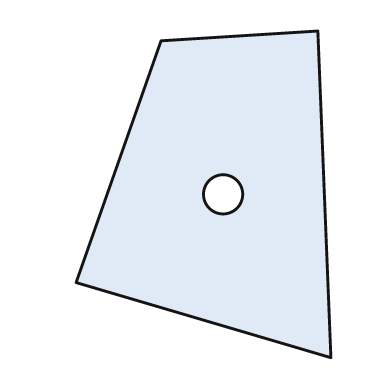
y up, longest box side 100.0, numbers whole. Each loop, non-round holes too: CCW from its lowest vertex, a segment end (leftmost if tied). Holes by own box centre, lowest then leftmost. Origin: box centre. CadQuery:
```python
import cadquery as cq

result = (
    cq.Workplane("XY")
    .moveTo(39.0, -50.0)
    .lineTo(35.0, 50.0)
    .lineTo(-13.0, 47.0)
    .lineTo(-39.0, -27.0)
    .close()
    .moveTo(6.0, 0.0)
    .circle(6.0)
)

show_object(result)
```